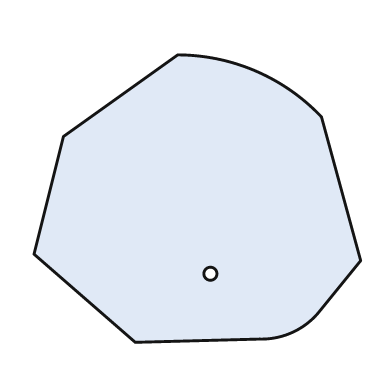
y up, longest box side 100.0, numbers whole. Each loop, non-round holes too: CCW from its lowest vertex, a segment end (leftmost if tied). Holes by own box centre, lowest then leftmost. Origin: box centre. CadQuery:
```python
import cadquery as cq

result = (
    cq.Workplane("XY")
    .moveTo(-19.0, -44.0)
    .lineTo(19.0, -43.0)
    .threePointArc((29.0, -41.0), (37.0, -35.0))
    .lineTo(50.0, -19.0)
    .lineTo(38.0, 25.0)
    .threePointArc((18.0, 39.0), (-6.0, 44.0))
    .lineTo(-41.0, 19.0)
    .lineTo(-50.0, -17.0)
    .close()
    .moveTo(4.0, -23.0)
    .circle(2.0)
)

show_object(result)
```